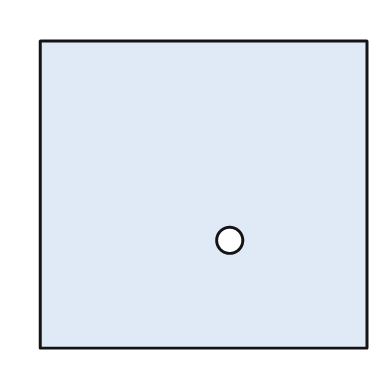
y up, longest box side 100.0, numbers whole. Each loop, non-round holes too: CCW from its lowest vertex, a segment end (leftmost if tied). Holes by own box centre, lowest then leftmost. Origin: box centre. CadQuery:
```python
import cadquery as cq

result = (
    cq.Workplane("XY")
    .moveTo(-50.0, -47.0)
    .lineTo(50.0, -47.0)
    .lineTo(50.0, 47.0)
    .lineTo(-50.0, 47.0)
    .close()
    .moveTo(8.0, -14.0)
    .circle(4.0)
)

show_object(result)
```